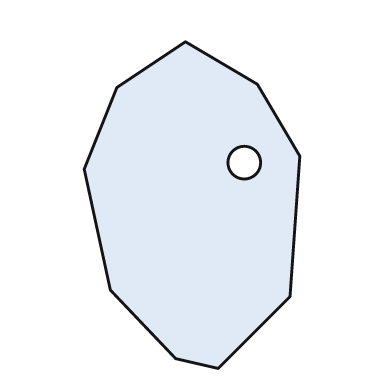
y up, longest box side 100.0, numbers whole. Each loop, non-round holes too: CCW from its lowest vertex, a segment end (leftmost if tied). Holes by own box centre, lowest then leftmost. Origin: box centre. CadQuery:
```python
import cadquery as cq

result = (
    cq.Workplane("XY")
    .moveTo(8.0, -50.0)
    .lineTo(30.0, -28.0)
    .lineTo(33.0, 15.0)
    .lineTo(20.0, 37.0)
    .lineTo(-2.0, 50.0)
    .lineTo(-23.0, 36.0)
    .lineTo(-33.0, 11.0)
    .lineTo(-25.0, -26.0)
    .lineTo(-5.0, -47.0)
    .close()
    .moveTo(16.0, 13.0)
    .circle(5.0)
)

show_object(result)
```